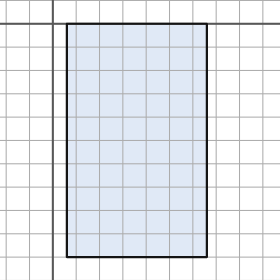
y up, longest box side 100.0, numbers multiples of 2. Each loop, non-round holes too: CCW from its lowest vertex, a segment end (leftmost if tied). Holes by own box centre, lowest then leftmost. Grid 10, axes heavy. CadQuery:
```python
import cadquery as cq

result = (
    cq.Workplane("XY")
    .moveTo(6.0, -100.0)
    .lineTo(66.0, -100.0)
    .lineTo(66.0, 0.0)
    .lineTo(6.0, 0.0)
    .close()
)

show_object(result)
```